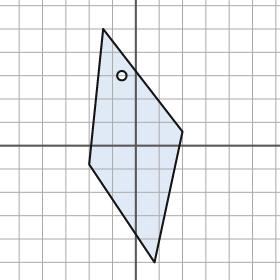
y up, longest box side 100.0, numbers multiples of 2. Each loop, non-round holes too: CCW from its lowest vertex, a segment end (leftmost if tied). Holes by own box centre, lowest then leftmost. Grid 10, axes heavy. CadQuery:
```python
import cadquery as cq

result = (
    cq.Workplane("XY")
    .moveTo(8.0, -50.0)
    .lineTo(20.0, 6.0)
    .lineTo(-14.0, 50.0)
    .lineTo(-20.0, -8.0)
    .close()
    .moveTo(-6.0, 30.0)
    .circle(2.0)
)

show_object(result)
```